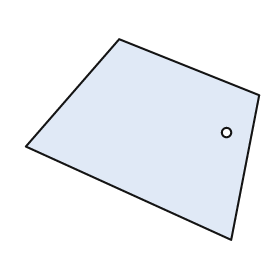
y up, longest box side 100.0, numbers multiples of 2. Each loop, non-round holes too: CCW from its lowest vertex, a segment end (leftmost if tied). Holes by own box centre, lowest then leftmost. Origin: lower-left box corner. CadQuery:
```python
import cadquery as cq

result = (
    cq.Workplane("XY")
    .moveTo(88.0, 0.0)
    .lineTo(100.0, 62.0)
    .lineTo(40.0, 86.0)
    .lineTo(0.0, 40.0)
    .close()
    .moveTo(86.0, 46.0)
    .circle(2.0)
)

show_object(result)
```